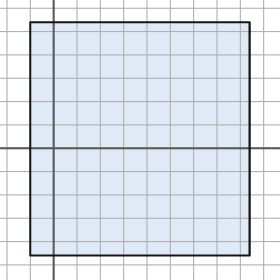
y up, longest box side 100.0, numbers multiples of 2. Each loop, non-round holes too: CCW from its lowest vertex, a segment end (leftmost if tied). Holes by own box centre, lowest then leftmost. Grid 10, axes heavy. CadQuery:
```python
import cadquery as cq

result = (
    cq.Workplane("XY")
    .moveTo(-10.0, -46.0)
    .lineTo(84.0, -46.0)
    .lineTo(84.0, 54.0)
    .lineTo(-10.0, 54.0)
    .close()
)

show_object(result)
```